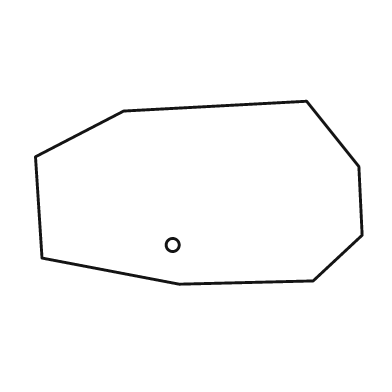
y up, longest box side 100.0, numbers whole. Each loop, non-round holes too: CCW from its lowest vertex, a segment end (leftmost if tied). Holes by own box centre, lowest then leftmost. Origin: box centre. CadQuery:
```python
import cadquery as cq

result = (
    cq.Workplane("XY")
    .moveTo(-6.0, -28.0)
    .lineTo(35.0, -27.0)
    .lineTo(50.0, -13.0)
    .lineTo(49.0, 8.0)
    .lineTo(33.0, 28.0)
    .lineTo(-23.0, 25.0)
    .lineTo(-50.0, 11.0)
    .lineTo(-48.0, -20.0)
    .close()
    .moveTo(-8.0, -16.0)
    .circle(2.0)
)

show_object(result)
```